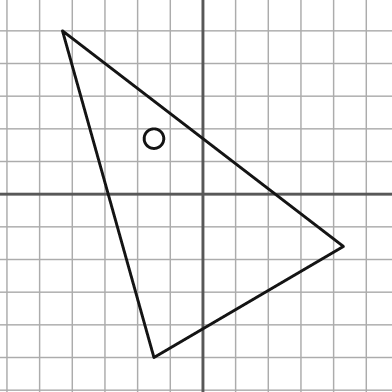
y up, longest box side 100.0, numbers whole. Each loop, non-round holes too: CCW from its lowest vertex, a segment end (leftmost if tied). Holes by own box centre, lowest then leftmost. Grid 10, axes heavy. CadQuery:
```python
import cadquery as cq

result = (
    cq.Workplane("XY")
    .moveTo(-15.0, -50.0)
    .lineTo(43.0, -16.0)
    .lineTo(-43.0, 50.0)
    .close()
    .moveTo(-15.0, 17.0)
    .circle(3.0)
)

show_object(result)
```